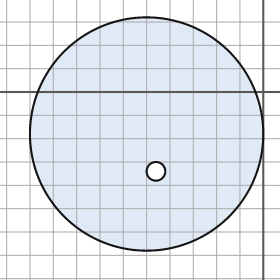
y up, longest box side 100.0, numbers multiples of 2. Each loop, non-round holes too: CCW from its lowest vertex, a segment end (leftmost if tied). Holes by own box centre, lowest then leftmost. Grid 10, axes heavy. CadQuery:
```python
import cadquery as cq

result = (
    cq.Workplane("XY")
    .moveTo(-50.0, -18.0)
    .circle(50.0)
    .moveTo(-46.0, -34.0)
    .circle(4.0)
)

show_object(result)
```